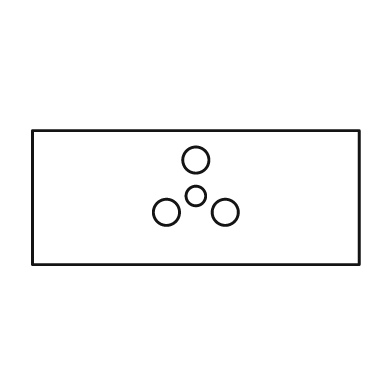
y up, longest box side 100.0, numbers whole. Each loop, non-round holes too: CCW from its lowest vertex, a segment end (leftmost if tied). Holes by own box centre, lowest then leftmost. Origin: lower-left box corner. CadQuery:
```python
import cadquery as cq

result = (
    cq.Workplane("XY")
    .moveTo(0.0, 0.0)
    .lineTo(100.0, 0.0)
    .lineTo(100.0, 41.0)
    .lineTo(0.0, 41.0)
    .close()
    .moveTo(41.0, 16.0)
    .circle(4.0)
    .moveTo(59.0, 16.0)
    .circle(4.0)
    .moveTo(50.0, 21.0)
    .circle(3.0)
    .moveTo(50.0, 32.0)
    .circle(4.0)
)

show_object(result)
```